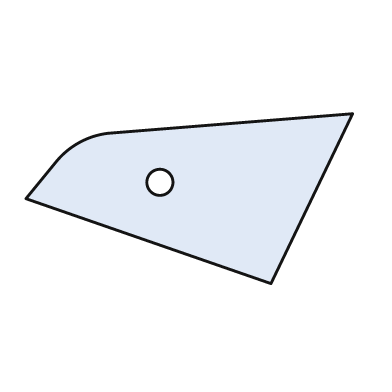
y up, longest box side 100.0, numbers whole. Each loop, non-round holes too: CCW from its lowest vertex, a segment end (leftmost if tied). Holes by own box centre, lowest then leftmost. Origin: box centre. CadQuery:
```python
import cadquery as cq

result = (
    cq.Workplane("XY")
    .moveTo(25.0, -26.0)
    .lineTo(50.0, 26.0)
    .lineTo(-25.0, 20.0)
    .threePointArc((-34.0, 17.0), (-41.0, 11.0))
    .lineTo(-50.0, 0.0)
    .close()
    .moveTo(-9.0, 5.0)
    .circle(4.0)
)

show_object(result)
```